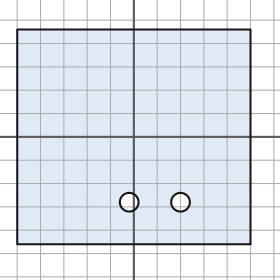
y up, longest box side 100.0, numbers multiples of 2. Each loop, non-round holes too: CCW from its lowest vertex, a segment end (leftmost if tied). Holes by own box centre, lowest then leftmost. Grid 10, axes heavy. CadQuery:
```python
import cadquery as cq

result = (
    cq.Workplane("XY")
    .moveTo(-50.0, -46.0)
    .lineTo(50.0, -46.0)
    .lineTo(50.0, 46.0)
    .lineTo(-50.0, 46.0)
    .close()
    .moveTo(-2.0, -28.0)
    .circle(4.0)
    .moveTo(20.0, -28.0)
    .circle(4.0)
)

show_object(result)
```